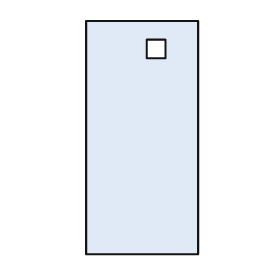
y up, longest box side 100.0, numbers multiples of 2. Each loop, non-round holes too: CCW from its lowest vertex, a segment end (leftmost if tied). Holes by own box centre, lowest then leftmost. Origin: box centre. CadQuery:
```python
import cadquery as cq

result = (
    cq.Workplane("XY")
    .moveTo(-24.0, -50.0)
    .lineTo(24.0, -50.0)
    .lineTo(24.0, 50.0)
    .lineTo(-24.0, 50.0)
    .close()
    .moveTo(2.0, 34.0)
    .lineTo(10.0, 34.0)
    .lineTo(10.0, 42.0)
    .lineTo(2.0, 42.0)
    .close()
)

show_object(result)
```